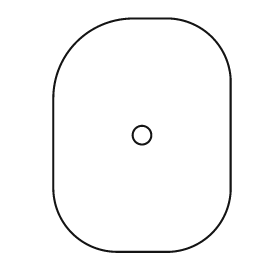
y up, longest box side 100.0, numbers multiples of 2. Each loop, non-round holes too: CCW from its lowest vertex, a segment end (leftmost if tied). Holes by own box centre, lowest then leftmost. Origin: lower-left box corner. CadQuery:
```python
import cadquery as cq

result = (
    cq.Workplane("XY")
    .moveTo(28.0, 0.0)
    .lineTo(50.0, 0.0)
    .threePointArc((68.0, 8.0), (76.0, 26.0))
    .lineTo(76.0, 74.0)
    .threePointArc((68.0, 92.0), (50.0, 100.0))
    .lineTo(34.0, 100.0)
    .threePointArc((10.0, 90.0), (0.0, 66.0))
    .lineTo(0.0, 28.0)
    .threePointArc((8.0, 8.0), (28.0, 0.0))
    .close()
    .moveTo(38.0, 50.0)
    .circle(4.0)
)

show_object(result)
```